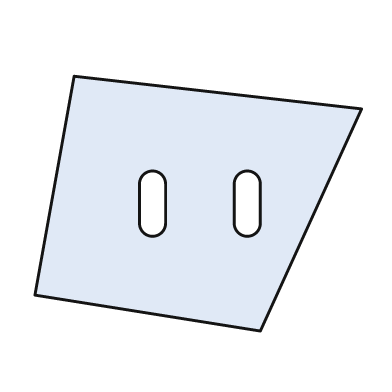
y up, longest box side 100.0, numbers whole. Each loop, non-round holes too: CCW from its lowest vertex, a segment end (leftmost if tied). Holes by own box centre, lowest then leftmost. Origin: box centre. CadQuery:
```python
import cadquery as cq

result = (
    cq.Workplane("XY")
    .moveTo(19.0, -39.0)
    .lineTo(50.0, 29.0)
    .lineTo(-38.0, 39.0)
    .lineTo(-50.0, -28.0)
    .close()
    .moveTo(-18.0, -6.0)
    .threePointArc((-14.0, -10.0), (-10.0, -6.0))
    .lineTo(-10.0, 6.0)
    .threePointArc((-14.0, 10.0), (-18.0, 6.0))
    .close()
    .moveTo(11.0, -6.0)
    .threePointArc((15.0, -10.0), (19.0, -6.0))
    .lineTo(19.0, 6.0)
    .threePointArc((15.0, 10.0), (11.0, 6.0))
    .close()
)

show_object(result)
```